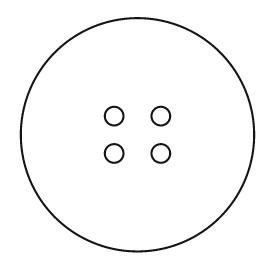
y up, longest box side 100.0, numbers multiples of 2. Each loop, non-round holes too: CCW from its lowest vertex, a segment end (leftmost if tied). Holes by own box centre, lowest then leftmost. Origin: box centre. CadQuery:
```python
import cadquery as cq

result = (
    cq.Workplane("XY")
    .moveTo(0.0, 0.0)
    .circle(50.0)
    .moveTo(-10.0, -8.0)
    .circle(4.0)
    .moveTo(10.0, -8.0)
    .circle(4.0)
    .moveTo(-10.0, 8.0)
    .circle(4.0)
    .moveTo(10.0, 8.0)
    .circle(4.0)
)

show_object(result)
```